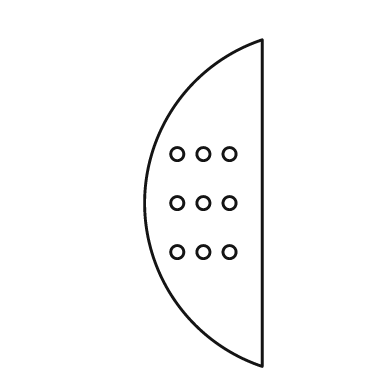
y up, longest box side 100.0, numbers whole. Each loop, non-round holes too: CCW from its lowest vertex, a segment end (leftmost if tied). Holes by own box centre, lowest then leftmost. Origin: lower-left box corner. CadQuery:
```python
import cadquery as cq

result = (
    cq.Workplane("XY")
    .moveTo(36.0, 0.0)
    .lineTo(36.0, 100.0)
    .threePointArc((0.0, 50.0), (36.0, 0.0))
    .close()
    .moveTo(10.0, 35.0)
    .circle(2.0)
    .moveTo(18.0, 35.0)
    .circle(2.0)
    .moveTo(26.0, 35.0)
    .circle(2.0)
    .moveTo(10.0, 50.0)
    .circle(2.0)
    .moveTo(18.0, 50.0)
    .circle(2.0)
    .moveTo(26.0, 50.0)
    .circle(2.0)
    .moveTo(10.0, 65.0)
    .circle(2.0)
    .moveTo(18.0, 65.0)
    .circle(2.0)
    .moveTo(26.0, 65.0)
    .circle(2.0)
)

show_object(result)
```